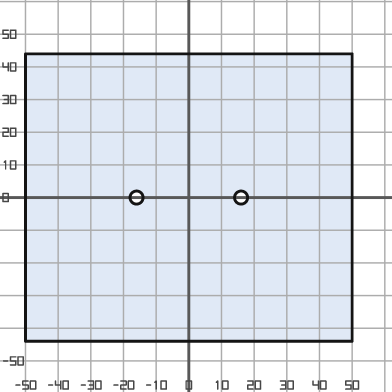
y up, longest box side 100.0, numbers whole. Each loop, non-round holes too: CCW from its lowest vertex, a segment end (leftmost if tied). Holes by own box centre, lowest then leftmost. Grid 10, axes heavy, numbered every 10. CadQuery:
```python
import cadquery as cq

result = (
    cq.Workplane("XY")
    .moveTo(-50.0, -44.0)
    .lineTo(50.0, -44.0)
    .lineTo(50.0, 44.0)
    .lineTo(-50.0, 44.0)
    .close()
    .moveTo(-16.0, 0.0)
    .circle(2.0)
    .moveTo(16.0, 0.0)
    .circle(2.0)
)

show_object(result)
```